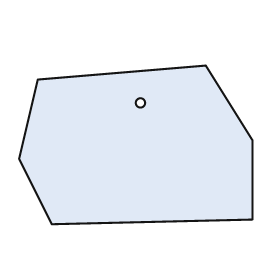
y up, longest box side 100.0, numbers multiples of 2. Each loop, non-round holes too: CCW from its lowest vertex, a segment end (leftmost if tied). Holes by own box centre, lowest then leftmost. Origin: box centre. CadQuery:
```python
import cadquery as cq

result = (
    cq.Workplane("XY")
    .moveTo(-36.0, -34.0)
    .lineTo(50.0, -32.0)
    .lineTo(50.0, 2.0)
    .lineTo(30.0, 34.0)
    .lineTo(-42.0, 28.0)
    .lineTo(-50.0, -6.0)
    .close()
    .moveTo(2.0, 18.0)
    .circle(2.0)
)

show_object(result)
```